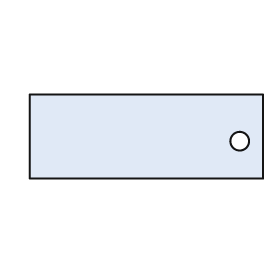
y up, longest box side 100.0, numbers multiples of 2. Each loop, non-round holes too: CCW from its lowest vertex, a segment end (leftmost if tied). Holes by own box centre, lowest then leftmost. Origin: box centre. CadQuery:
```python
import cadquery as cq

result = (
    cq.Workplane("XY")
    .moveTo(-50.0, -18.0)
    .lineTo(50.0, -18.0)
    .lineTo(50.0, 18.0)
    .lineTo(-50.0, 18.0)
    .close()
    .moveTo(40.0, -2.0)
    .circle(4.0)
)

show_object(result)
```